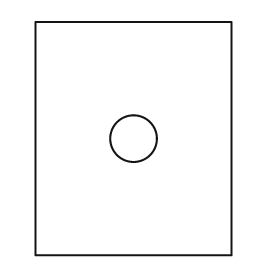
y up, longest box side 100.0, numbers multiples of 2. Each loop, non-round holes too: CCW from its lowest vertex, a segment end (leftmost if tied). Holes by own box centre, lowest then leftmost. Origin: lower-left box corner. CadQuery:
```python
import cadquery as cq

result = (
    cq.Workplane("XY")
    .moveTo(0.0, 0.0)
    .lineTo(84.0, 0.0)
    .lineTo(84.0, 100.0)
    .lineTo(0.0, 100.0)
    .close()
    .moveTo(42.0, 50.0)
    .circle(10.0)
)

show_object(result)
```